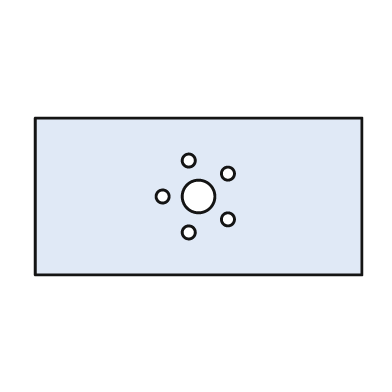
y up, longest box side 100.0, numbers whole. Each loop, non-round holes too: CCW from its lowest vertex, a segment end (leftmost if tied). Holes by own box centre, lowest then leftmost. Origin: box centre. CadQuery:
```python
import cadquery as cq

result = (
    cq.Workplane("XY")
    .moveTo(-50.0, -24.0)
    .lineTo(50.0, -24.0)
    .lineTo(50.0, 24.0)
    .lineTo(-50.0, 24.0)
    .close()
    .moveTo(-3.0, -11.0)
    .circle(2.0)
    .moveTo(9.0, -7.0)
    .circle(2.0)
    .moveTo(-11.0, 0.0)
    .circle(2.0)
    .moveTo(0.0, 0.0)
    .circle(5.0)
    .moveTo(9.0, 7.0)
    .circle(2.0)
    .moveTo(-3.0, 11.0)
    .circle(2.0)
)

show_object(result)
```